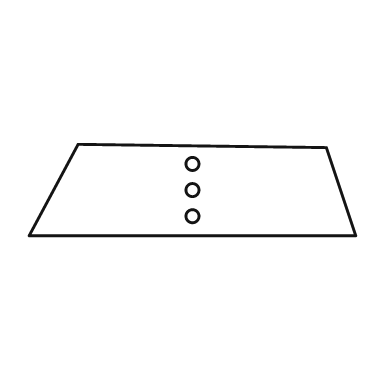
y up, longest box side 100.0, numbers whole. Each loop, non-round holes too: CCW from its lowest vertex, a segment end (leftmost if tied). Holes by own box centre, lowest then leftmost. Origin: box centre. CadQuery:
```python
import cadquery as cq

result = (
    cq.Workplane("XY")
    .moveTo(-50.0, -14.0)
    .lineTo(50.0, -14.0)
    .lineTo(41.0, 13.0)
    .lineTo(-35.0, 14.0)
    .close()
    .moveTo(0.0, -8.0)
    .circle(2.0)
    .moveTo(0.0, 0.0)
    .circle(2.0)
    .moveTo(0.0, 8.0)
    .circle(2.0)
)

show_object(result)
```